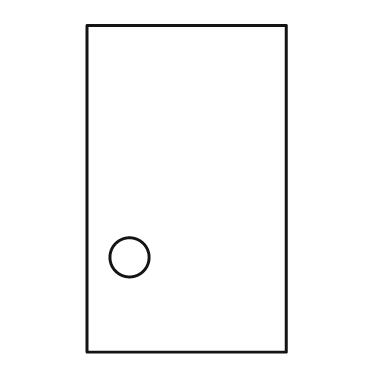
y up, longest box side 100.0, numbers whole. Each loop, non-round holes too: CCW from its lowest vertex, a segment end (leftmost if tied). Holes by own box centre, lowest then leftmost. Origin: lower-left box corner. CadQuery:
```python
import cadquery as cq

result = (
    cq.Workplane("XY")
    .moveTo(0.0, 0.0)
    .lineTo(61.0, 0.0)
    .lineTo(61.0, 100.0)
    .lineTo(0.0, 100.0)
    .close()
    .moveTo(13.0, 29.0)
    .circle(6.0)
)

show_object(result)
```